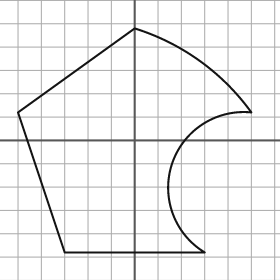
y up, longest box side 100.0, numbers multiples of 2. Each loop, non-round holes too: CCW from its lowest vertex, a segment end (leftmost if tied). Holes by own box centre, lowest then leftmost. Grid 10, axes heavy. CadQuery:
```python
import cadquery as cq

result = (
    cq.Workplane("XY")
    .moveTo(-30.0, -48.0)
    .lineTo(30.0, -48.0)
    .threePointArc((16.0, -10.0), (50.0, 12.0))
    .threePointArc((28.0, 34.0), (0.0, 48.0))
    .lineTo(-50.0, 12.0)
    .close()
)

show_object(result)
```